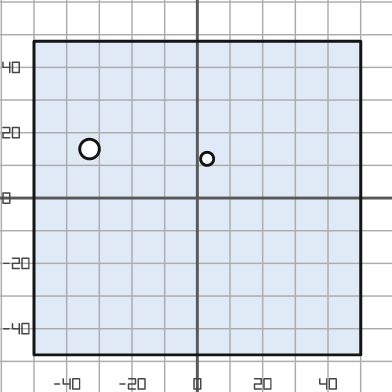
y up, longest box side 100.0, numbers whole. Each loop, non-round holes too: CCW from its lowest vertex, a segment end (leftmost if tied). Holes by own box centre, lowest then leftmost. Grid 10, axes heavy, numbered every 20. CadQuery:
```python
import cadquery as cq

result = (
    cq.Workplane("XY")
    .moveTo(-50.0, -48.0)
    .lineTo(50.0, -48.0)
    .lineTo(50.0, 48.0)
    .lineTo(-50.0, 48.0)
    .close()
    .moveTo(3.0, 12.0)
    .circle(2.0)
    .moveTo(-33.0, 15.0)
    .circle(3.0)
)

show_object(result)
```